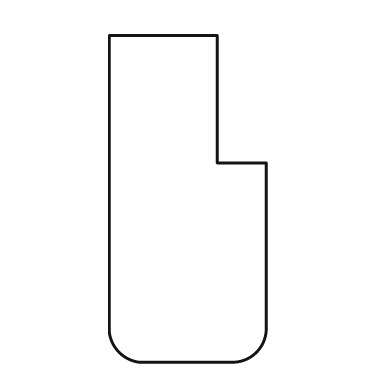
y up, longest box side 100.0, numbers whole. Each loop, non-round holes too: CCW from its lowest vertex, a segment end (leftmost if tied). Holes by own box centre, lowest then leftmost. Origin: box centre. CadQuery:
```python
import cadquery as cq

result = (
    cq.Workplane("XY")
    .moveTo(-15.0, -50.0)
    .lineTo(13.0, -50.0)
    .threePointArc((21.0, -47.0), (24.0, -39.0))
    .lineTo(24.0, 11.0)
    .lineTo(9.0, 11.0)
    .lineTo(9.0, 50.0)
    .lineTo(-24.0, 50.0)
    .lineTo(-24.0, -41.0)
    .threePointArc((-21.0, -47.0), (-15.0, -50.0))
    .close()
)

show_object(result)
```